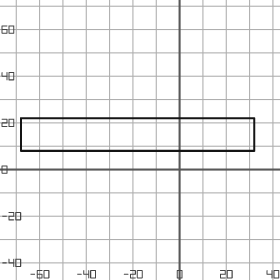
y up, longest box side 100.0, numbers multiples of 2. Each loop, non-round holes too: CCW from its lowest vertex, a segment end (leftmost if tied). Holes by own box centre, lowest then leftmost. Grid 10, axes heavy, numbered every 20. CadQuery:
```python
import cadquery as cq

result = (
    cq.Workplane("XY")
    .moveTo(-68.0, 8.0)
    .lineTo(32.0, 8.0)
    .lineTo(32.0, 22.0)
    .lineTo(-68.0, 22.0)
    .close()
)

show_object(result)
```